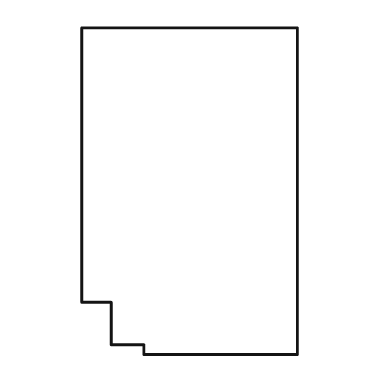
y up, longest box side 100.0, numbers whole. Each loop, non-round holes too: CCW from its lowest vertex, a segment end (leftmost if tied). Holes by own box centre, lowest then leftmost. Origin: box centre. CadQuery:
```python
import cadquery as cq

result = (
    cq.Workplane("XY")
    .moveTo(-14.0, -50.0)
    .lineTo(33.0, -50.0)
    .lineTo(33.0, 50.0)
    .lineTo(-33.0, 50.0)
    .lineTo(-33.0, -34.0)
    .lineTo(-24.0, -34.0)
    .lineTo(-24.0, -47.0)
    .lineTo(-14.0, -47.0)
    .close()
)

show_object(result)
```